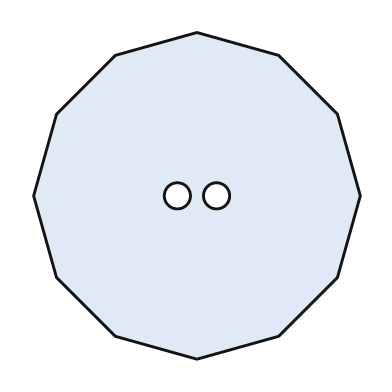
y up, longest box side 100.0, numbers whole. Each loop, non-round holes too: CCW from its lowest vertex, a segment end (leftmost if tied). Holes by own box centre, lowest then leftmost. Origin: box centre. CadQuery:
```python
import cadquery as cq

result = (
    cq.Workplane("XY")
    .moveTo(0.0, -50.0)
    .lineTo(25.0, -43.0)
    .lineTo(43.0, -25.0)
    .lineTo(50.0, 0.0)
    .lineTo(43.0, 25.0)
    .lineTo(25.0, 43.0)
    .lineTo(0.0, 50.0)
    .lineTo(-25.0, 43.0)
    .lineTo(-43.0, 25.0)
    .lineTo(-50.0, 0.0)
    .lineTo(-43.0, -25.0)
    .lineTo(-25.0, -43.0)
    .close()
    .moveTo(-6.0, 0.0)
    .circle(4.0)
    .moveTo(6.0, 0.0)
    .circle(4.0)
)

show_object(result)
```